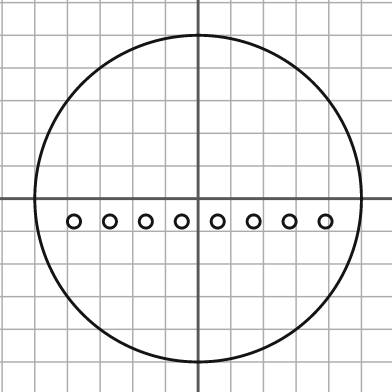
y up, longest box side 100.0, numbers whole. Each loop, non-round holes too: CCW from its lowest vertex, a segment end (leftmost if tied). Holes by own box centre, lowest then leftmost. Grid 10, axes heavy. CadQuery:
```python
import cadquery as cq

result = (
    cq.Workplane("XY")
    .moveTo(0.0, 0.0)
    .circle(50.0)
    .moveTo(-38.0, -7.0)
    .circle(2.0)
    .moveTo(-27.0, -7.0)
    .circle(2.0)
    .moveTo(-16.0, -7.0)
    .circle(2.0)
    .moveTo(-5.0, -7.0)
    .circle(2.0)
    .moveTo(6.0, -7.0)
    .circle(2.0)
    .moveTo(17.0, -7.0)
    .circle(2.0)
    .moveTo(28.0, -7.0)
    .circle(2.0)
    .moveTo(39.0, -7.0)
    .circle(2.0)
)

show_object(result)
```